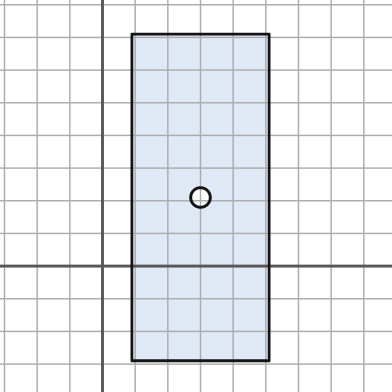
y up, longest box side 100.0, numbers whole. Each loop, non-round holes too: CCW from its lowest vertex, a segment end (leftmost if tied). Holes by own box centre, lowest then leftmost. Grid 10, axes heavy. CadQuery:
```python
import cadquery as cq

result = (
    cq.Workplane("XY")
    .moveTo(9.0, -29.0)
    .lineTo(51.0, -29.0)
    .lineTo(51.0, 71.0)
    .lineTo(9.0, 71.0)
    .close()
    .moveTo(30.0, 21.0)
    .circle(3.0)
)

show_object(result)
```